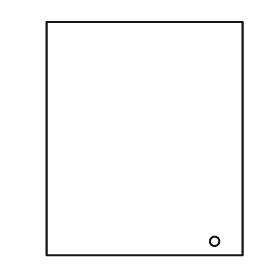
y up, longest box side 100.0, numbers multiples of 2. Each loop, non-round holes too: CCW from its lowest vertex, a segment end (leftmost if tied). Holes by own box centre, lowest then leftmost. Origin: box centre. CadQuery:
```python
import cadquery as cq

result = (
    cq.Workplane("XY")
    .moveTo(-42.0, -50.0)
    .lineTo(42.0, -50.0)
    .lineTo(42.0, 50.0)
    .lineTo(-42.0, 50.0)
    .close()
    .moveTo(30.0, -44.0)
    .circle(2.0)
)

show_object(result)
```